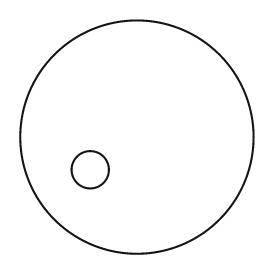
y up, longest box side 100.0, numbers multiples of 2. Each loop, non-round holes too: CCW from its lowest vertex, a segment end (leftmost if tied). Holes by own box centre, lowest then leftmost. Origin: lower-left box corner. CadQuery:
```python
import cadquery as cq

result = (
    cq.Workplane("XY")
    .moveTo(50.0, 50.0)
    .circle(50.0)
    .moveTo(30.0, 36.0)
    .circle(8.0)
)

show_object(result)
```